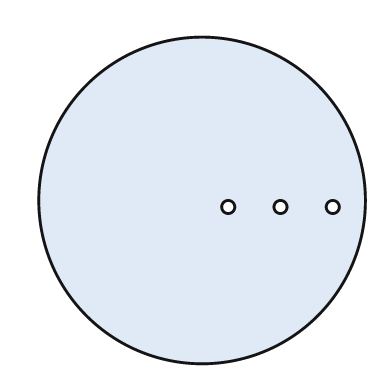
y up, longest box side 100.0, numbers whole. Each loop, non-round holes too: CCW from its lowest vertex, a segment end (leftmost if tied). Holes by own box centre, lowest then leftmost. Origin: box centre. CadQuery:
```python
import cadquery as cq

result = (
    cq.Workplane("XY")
    .moveTo(0.0, 0.0)
    .circle(50.0)
    .moveTo(8.0, -2.0)
    .circle(2.0)
    .moveTo(24.0, -2.0)
    .circle(2.0)
    .moveTo(40.0, -2.0)
    .circle(2.0)
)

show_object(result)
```